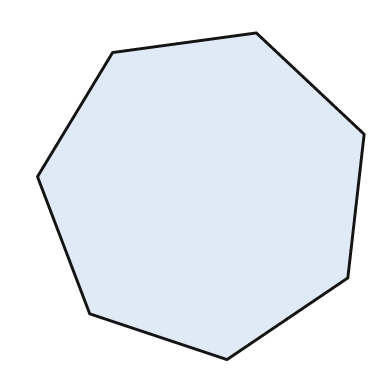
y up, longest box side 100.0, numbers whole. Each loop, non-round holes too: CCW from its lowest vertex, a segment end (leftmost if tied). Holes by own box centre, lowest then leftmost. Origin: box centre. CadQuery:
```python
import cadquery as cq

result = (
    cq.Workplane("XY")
    .moveTo(8.0, -50.0)
    .lineTo(45.0, -25.0)
    .lineTo(50.0, 19.0)
    .lineTo(17.0, 50.0)
    .lineTo(-27.0, 44.0)
    .lineTo(-50.0, 6.0)
    .lineTo(-34.0, -36.0)
    .close()
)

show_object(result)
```